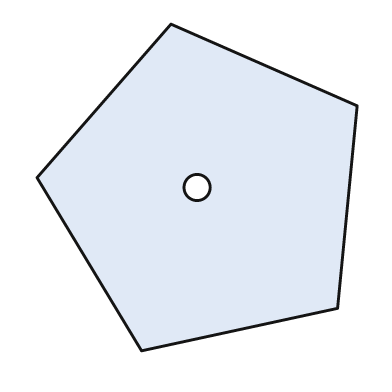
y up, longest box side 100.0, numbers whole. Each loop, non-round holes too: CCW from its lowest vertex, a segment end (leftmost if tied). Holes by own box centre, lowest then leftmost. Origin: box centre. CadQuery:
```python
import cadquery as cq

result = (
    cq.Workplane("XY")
    .moveTo(-17.0, -50.0)
    .lineTo(43.0, -37.0)
    .lineTo(49.0, 25.0)
    .lineTo(-8.0, 50.0)
    .lineTo(-49.0, 3.0)
    .close()
    .moveTo(0.0, 0.0)
    .circle(4.0)
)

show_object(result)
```